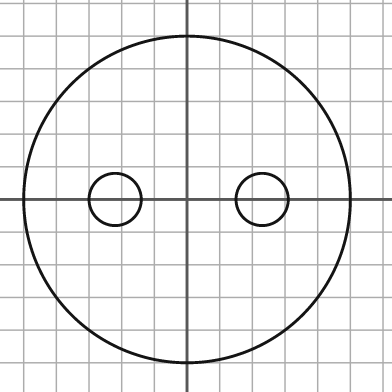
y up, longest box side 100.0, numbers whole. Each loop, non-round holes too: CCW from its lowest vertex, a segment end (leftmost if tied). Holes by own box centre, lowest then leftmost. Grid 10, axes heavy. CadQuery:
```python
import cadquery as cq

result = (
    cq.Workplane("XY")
    .moveTo(0.0, 0.0)
    .circle(50.0)
    .moveTo(-22.0, 0.0)
    .circle(8.0)
    .moveTo(23.0, 0.0)
    .circle(8.0)
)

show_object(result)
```